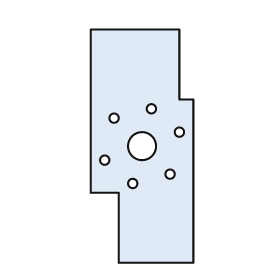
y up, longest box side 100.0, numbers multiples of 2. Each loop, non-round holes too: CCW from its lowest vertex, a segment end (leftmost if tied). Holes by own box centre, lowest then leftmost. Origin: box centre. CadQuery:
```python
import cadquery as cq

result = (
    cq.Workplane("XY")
    .moveTo(-10.0, -50.0)
    .lineTo(22.0, -50.0)
    .lineTo(22.0, 20.0)
    .lineTo(16.0, 20.0)
    .lineTo(16.0, 50.0)
    .lineTo(-22.0, 50.0)
    .lineTo(-22.0, -20.0)
    .lineTo(-10.0, -20.0)
    .close()
    .moveTo(-4.0, -16.0)
    .circle(2.0)
    .moveTo(12.0, -12.0)
    .circle(2.0)
    .moveTo(-16.0, -6.0)
    .circle(2.0)
    .moveTo(0.0, 0.0)
    .circle(6.0)
    .moveTo(16.0, 6.0)
    .circle(2.0)
    .moveTo(-12.0, 12.0)
    .circle(2.0)
    .moveTo(4.0, 16.0)
    .circle(2.0)
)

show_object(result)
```